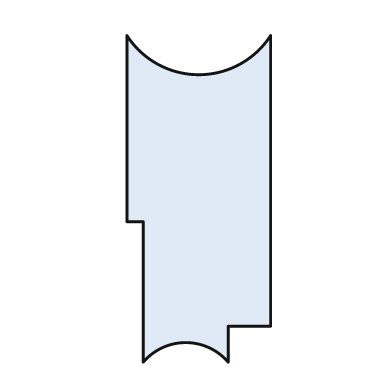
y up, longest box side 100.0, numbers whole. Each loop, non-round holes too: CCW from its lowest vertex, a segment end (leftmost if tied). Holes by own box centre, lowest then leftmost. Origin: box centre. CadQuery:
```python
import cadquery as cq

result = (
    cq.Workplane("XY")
    .moveTo(-17.0, -50.0)
    .threePointArc((-4.0, -44.0), (9.0, -50.0))
    .lineTo(9.0, -39.0)
    .lineTo(22.0, -39.0)
    .lineTo(22.0, 50.0)
    .threePointArc((0.0, 38.0), (-22.0, 50.0))
    .lineTo(-22.0, -7.0)
    .lineTo(-17.0, -7.0)
    .close()
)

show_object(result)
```